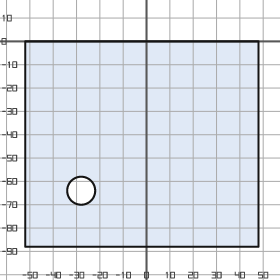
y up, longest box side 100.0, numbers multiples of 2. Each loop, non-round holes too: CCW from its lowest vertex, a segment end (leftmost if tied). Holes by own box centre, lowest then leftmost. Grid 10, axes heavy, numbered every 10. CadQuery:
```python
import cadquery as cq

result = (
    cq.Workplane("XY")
    .moveTo(-52.0, -88.0)
    .lineTo(48.0, -88.0)
    .lineTo(48.0, 0.0)
    .lineTo(-52.0, 0.0)
    .close()
    .moveTo(-28.0, -64.0)
    .circle(6.0)
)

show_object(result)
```